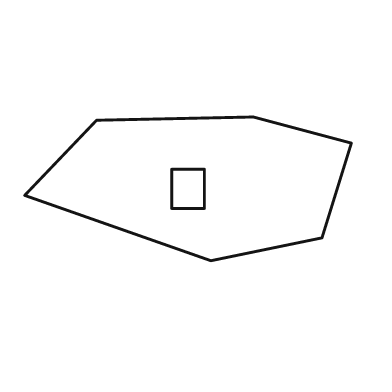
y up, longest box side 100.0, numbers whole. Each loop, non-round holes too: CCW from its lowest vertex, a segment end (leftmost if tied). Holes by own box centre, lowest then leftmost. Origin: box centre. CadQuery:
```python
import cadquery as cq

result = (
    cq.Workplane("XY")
    .moveTo(7.0, -22.0)
    .lineTo(41.0, -15.0)
    .lineTo(50.0, 14.0)
    .lineTo(20.0, 22.0)
    .lineTo(-28.0, 21.0)
    .lineTo(-50.0, -2.0)
    .close()
    .moveTo(-5.0, -6.0)
    .lineTo(5.0, -6.0)
    .lineTo(5.0, 6.0)
    .lineTo(-5.0, 6.0)
    .close()
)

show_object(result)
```